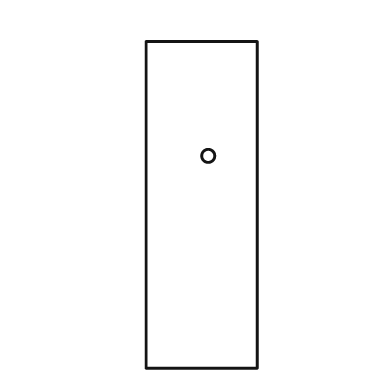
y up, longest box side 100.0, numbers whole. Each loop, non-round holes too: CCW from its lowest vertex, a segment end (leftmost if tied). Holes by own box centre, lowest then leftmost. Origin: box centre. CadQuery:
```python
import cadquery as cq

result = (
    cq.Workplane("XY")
    .moveTo(-17.0, -50.0)
    .lineTo(17.0, -50.0)
    .lineTo(17.0, 50.0)
    .lineTo(-17.0, 50.0)
    .close()
    .moveTo(2.0, 15.0)
    .circle(2.0)
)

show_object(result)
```